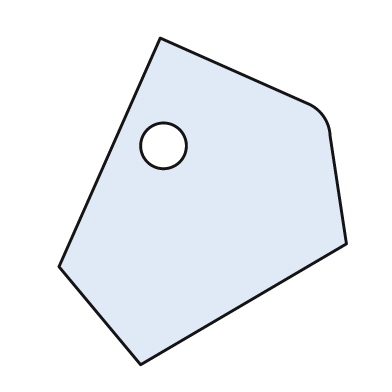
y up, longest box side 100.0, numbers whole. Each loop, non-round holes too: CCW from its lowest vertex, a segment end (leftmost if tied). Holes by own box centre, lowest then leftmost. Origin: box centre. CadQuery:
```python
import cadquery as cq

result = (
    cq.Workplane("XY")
    .moveTo(-19.0, -50.0)
    .lineTo(44.0, -13.0)
    .lineTo(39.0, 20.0)
    .threePointArc((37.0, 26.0), (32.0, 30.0))
    .lineTo(-13.0, 50.0)
    .lineTo(-44.0, -20.0)
    .close()
    .moveTo(-12.0, 17.0)
    .circle(7.0)
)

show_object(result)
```